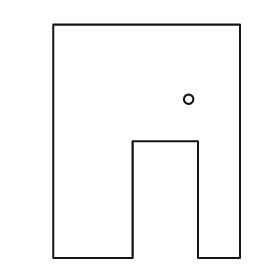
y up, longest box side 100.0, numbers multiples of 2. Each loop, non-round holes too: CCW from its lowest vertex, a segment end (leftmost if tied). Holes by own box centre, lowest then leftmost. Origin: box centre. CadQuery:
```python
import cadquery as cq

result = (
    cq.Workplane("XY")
    .moveTo(-40.0, -50.0)
    .lineTo(-6.0, -50.0)
    .lineTo(-6.0, 0.0)
    .lineTo(22.0, 0.0)
    .lineTo(22.0, -50.0)
    .lineTo(40.0, -50.0)
    .lineTo(40.0, 50.0)
    .lineTo(-40.0, 50.0)
    .close()
    .moveTo(18.0, 18.0)
    .circle(2.0)
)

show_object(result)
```